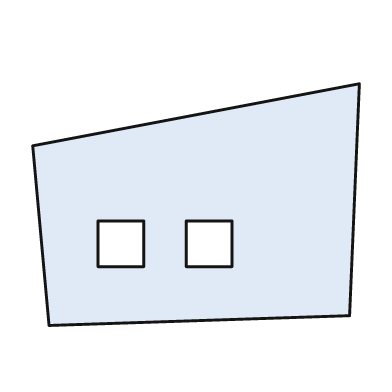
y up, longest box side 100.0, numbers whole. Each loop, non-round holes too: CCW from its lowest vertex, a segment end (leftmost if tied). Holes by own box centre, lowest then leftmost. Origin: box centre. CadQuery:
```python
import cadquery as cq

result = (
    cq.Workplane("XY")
    .moveTo(-45.0, -37.0)
    .lineTo(47.0, -34.0)
    .lineTo(50.0, 37.0)
    .lineTo(-50.0, 18.0)
    .close()
    .moveTo(-30.0, -19.0)
    .lineTo(-16.0, -19.0)
    .lineTo(-16.0, -5.0)
    .lineTo(-30.0, -5.0)
    .close()
    .moveTo(-3.0, -19.0)
    .lineTo(11.0, -19.0)
    .lineTo(11.0, -5.0)
    .lineTo(-3.0, -5.0)
    .close()
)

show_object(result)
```